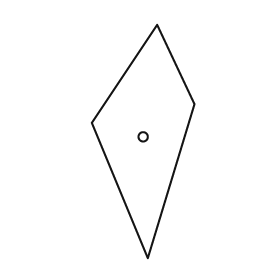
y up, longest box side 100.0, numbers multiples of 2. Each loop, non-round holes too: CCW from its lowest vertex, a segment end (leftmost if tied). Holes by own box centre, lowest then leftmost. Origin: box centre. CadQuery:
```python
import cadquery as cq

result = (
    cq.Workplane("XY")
    .moveTo(2.0, -50.0)
    .lineTo(22.0, 16.0)
    .lineTo(6.0, 50.0)
    .lineTo(-22.0, 8.0)
    .close()
    .moveTo(0.0, 2.0)
    .circle(2.0)
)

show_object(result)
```